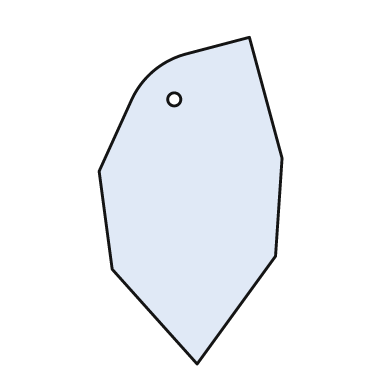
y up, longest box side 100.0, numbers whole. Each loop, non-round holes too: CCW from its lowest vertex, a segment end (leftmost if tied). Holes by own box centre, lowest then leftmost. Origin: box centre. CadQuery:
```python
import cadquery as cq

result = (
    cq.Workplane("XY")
    .moveTo(2.0, -50.0)
    .lineTo(26.0, -17.0)
    .lineTo(28.0, 13.0)
    .lineTo(18.0, 50.0)
    .lineTo(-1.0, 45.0)
    .threePointArc((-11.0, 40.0), (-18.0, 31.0))
    .lineTo(-28.0, 9.0)
    .lineTo(-24.0, -21.0)
    .close()
    .moveTo(-5.0, 31.0)
    .circle(2.0)
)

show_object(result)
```